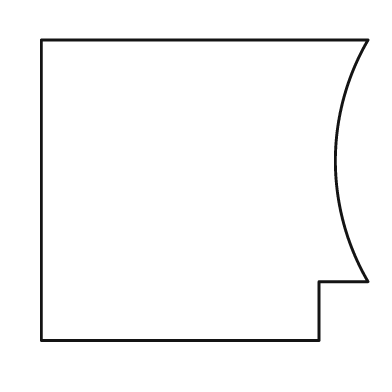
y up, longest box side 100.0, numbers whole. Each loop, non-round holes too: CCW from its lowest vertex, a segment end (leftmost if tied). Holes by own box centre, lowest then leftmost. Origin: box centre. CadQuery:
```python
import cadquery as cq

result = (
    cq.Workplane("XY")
    .moveTo(-50.0, -46.0)
    .lineTo(35.0, -46.0)
    .lineTo(35.0, -28.0)
    .lineTo(50.0, -28.0)
    .threePointArc((40.0, 9.0), (50.0, 46.0))
    .lineTo(-50.0, 46.0)
    .close()
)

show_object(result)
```